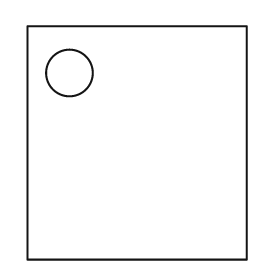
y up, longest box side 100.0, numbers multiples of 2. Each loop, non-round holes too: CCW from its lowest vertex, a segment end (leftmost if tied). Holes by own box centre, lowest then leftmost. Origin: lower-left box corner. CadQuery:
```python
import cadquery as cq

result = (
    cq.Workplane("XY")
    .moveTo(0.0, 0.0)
    .lineTo(94.0, 0.0)
    .lineTo(94.0, 100.0)
    .lineTo(0.0, 100.0)
    .close()
    .moveTo(18.0, 80.0)
    .circle(10.0)
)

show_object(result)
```